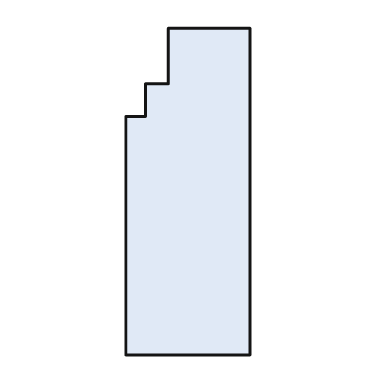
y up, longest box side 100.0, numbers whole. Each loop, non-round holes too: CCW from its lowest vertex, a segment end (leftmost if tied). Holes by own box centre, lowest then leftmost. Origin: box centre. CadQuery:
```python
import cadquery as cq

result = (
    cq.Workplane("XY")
    .moveTo(-19.0, -50.0)
    .lineTo(19.0, -50.0)
    .lineTo(19.0, 50.0)
    .lineTo(-6.0, 50.0)
    .lineTo(-6.0, 33.0)
    .lineTo(-13.0, 33.0)
    .lineTo(-13.0, 23.0)
    .lineTo(-19.0, 23.0)
    .close()
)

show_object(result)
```